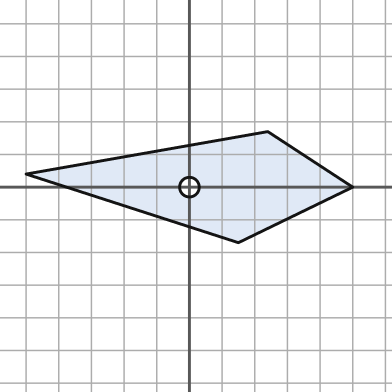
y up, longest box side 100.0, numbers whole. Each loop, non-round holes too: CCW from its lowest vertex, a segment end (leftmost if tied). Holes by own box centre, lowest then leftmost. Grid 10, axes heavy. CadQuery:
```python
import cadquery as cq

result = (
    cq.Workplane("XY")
    .moveTo(15.0, -17.0)
    .lineTo(50.0, 0.0)
    .lineTo(24.0, 17.0)
    .lineTo(-50.0, 4.0)
    .close()
    .moveTo(0.0, 0.0)
    .circle(3.0)
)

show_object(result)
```